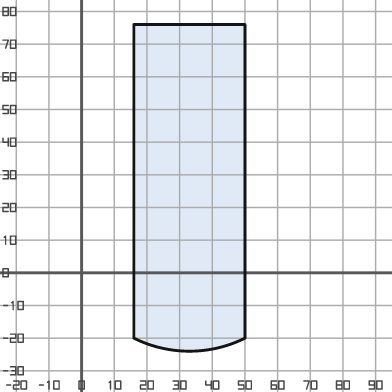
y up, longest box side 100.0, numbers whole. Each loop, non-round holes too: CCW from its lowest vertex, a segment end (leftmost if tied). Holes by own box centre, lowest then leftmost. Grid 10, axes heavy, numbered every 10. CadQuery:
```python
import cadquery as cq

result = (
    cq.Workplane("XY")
    .moveTo(16.0, -20.0)
    .threePointArc((33.0, -24.0), (50.0, -20.0))
    .lineTo(50.0, 76.0)
    .lineTo(16.0, 76.0)
    .close()
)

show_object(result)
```